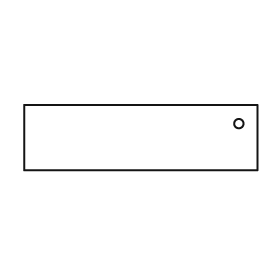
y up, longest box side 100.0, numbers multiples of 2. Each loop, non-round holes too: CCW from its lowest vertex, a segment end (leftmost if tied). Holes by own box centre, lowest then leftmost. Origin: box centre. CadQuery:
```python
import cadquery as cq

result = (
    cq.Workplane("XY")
    .moveTo(-50.0, -14.0)
    .lineTo(50.0, -14.0)
    .lineTo(50.0, 14.0)
    .lineTo(-50.0, 14.0)
    .close()
    .moveTo(42.0, 6.0)
    .circle(2.0)
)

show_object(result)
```